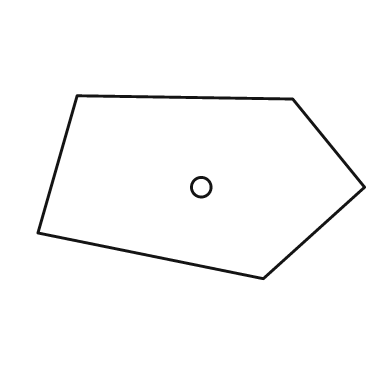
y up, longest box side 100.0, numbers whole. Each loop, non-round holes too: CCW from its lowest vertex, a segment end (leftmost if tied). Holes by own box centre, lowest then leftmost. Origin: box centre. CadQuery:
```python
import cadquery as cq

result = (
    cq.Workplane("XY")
    .moveTo(19.0, -28.0)
    .lineTo(50.0, 0.0)
    .lineTo(28.0, 27.0)
    .lineTo(-38.0, 28.0)
    .lineTo(-50.0, -14.0)
    .close()
    .moveTo(0.0, 0.0)
    .circle(3.0)
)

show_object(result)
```